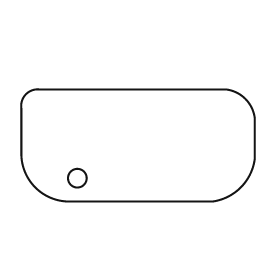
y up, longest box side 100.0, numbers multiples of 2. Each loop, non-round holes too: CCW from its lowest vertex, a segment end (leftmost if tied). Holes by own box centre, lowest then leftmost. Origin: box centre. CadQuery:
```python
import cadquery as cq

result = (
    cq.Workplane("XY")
    .moveTo(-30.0, -24.0)
    .lineTo(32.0, -24.0)
    .threePointArc((44.0, -18.0), (50.0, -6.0))
    .lineTo(50.0, 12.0)
    .threePointArc((46.0, 20.0), (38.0, 24.0))
    .lineTo(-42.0, 24.0)
    .threePointArc((-48.0, 22.0), (-50.0, 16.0))
    .lineTo(-50.0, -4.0)
    .threePointArc((-44.0, -18.0), (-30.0, -24.0))
    .close()
    .moveTo(-26.0, -14.0)
    .circle(4.0)
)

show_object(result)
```